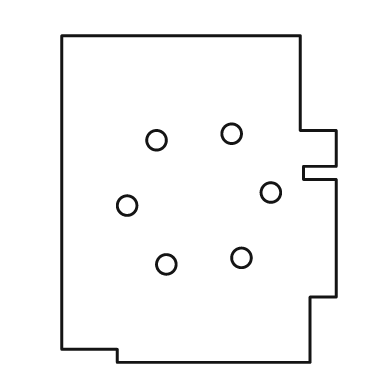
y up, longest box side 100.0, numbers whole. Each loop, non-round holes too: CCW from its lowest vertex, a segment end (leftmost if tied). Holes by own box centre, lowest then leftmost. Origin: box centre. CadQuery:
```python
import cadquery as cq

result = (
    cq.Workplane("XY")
    .moveTo(-25.0, -50.0)
    .lineTo(34.0, -50.0)
    .lineTo(34.0, -30.0)
    .lineTo(42.0, -30.0)
    .lineTo(42.0, 6.0)
    .lineTo(32.0, 6.0)
    .lineTo(32.0, 10.0)
    .lineTo(42.0, 10.0)
    .lineTo(42.0, 21.0)
    .lineTo(31.0, 21.0)
    .lineTo(31.0, 50.0)
    .lineTo(-42.0, 50.0)
    .lineTo(-42.0, -46.0)
    .lineTo(-25.0, -46.0)
    .close()
    .moveTo(-10.0, -20.0)
    .circle(3.0)
    .moveTo(13.0, -18.0)
    .circle(3.0)
    .moveTo(-22.0, -2.0)
    .circle(3.0)
    .moveTo(22.0, 2.0)
    .circle(3.0)
    .moveTo(-13.0, 18.0)
    .circle(3.0)
    .moveTo(10.0, 20.0)
    .circle(3.0)
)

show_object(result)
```